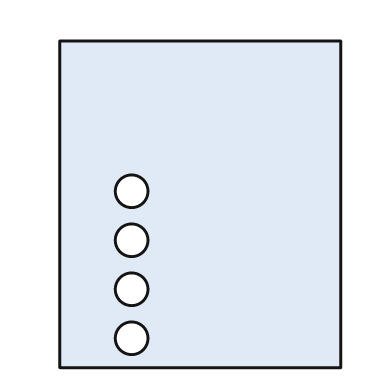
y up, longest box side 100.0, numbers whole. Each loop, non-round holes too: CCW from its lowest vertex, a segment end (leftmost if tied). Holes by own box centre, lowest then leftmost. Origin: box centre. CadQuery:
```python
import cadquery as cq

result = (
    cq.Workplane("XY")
    .moveTo(-43.0, -50.0)
    .lineTo(43.0, -50.0)
    .lineTo(43.0, 50.0)
    .lineTo(-43.0, 50.0)
    .close()
    .moveTo(-21.0, -41.0)
    .circle(5.0)
    .moveTo(-21.0, -26.0)
    .circle(5.0)
    .moveTo(-21.0, -11.0)
    .circle(5.0)
    .moveTo(-21.0, 4.0)
    .circle(5.0)
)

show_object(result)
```